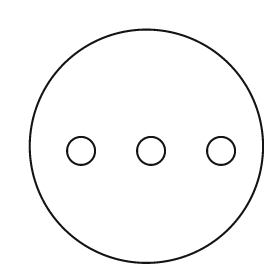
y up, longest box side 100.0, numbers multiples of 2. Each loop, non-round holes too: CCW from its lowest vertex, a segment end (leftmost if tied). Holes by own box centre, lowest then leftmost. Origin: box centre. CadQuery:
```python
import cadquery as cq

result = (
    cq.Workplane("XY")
    .moveTo(0.0, 0.0)
    .circle(50.0)
    .moveTo(-28.0, -2.0)
    .circle(6.0)
    .moveTo(2.0, -2.0)
    .circle(6.0)
    .moveTo(32.0, -2.0)
    .circle(6.0)
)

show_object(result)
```